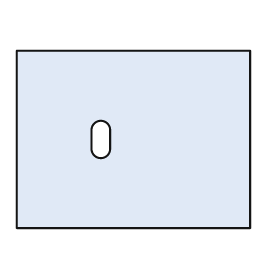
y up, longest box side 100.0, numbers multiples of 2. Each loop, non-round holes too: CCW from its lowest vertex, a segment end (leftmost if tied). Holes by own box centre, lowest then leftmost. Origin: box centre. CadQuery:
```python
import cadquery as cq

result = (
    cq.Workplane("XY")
    .moveTo(-50.0, -38.0)
    .lineTo(50.0, -38.0)
    .lineTo(50.0, 38.0)
    .lineTo(-50.0, 38.0)
    .close()
    .moveTo(-18.0, -4.0)
    .threePointArc((-14.0, -8.0), (-10.0, -4.0))
    .lineTo(-10.0, 4.0)
    .threePointArc((-14.0, 8.0), (-18.0, 4.0))
    .close()
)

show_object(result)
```